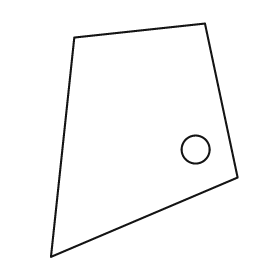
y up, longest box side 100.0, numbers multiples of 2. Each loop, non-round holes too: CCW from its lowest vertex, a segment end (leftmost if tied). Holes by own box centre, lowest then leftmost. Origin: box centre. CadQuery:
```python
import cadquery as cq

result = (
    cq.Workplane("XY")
    .moveTo(-40.0, -50.0)
    .lineTo(40.0, -16.0)
    .lineTo(26.0, 50.0)
    .lineTo(-30.0, 44.0)
    .close()
    .moveTo(22.0, -4.0)
    .circle(6.0)
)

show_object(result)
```